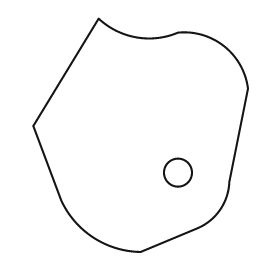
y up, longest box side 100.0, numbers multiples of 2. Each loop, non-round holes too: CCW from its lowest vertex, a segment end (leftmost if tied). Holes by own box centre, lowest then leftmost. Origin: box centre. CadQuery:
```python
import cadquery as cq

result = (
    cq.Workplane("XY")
    .moveTo(0.0, -50.0)
    .lineTo(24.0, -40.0)
    .threePointArc((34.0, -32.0), (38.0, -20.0))
    .lineTo(46.0, 20.0)
    .threePointArc((36.0, 38.0), (16.0, 44.0))
    .threePointArc((-2.0, 42.0), (-18.0, 50.0))
    .lineTo(-46.0, 4.0)
    .lineTo(-34.0, -28.0)
    .threePointArc((-20.0, -44.0), (0.0, -50.0))
    .close()
    .moveTo(16.0, -16.0)
    .circle(6.0)
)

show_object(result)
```